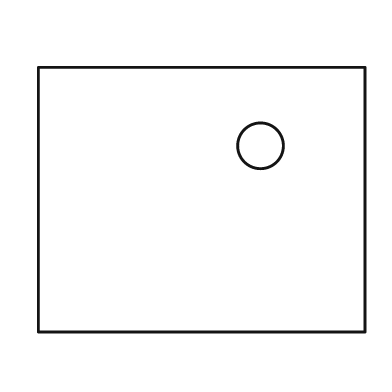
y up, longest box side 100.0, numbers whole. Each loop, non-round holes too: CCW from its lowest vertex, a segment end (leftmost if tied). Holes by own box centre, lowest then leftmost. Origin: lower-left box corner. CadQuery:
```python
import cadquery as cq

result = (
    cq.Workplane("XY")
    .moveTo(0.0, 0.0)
    .lineTo(100.0, 0.0)
    .lineTo(100.0, 81.0)
    .lineTo(0.0, 81.0)
    .close()
    .moveTo(68.0, 57.0)
    .circle(7.0)
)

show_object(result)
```